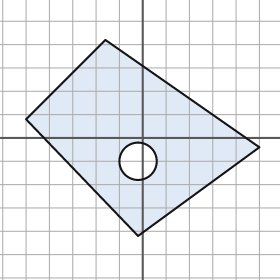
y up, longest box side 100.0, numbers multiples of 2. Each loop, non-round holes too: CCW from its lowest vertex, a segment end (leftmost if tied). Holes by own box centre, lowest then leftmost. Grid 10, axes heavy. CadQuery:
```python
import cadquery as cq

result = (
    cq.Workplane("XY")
    .moveTo(-2.0, -42.0)
    .lineTo(50.0, -4.0)
    .lineTo(-16.0, 42.0)
    .lineTo(-50.0, 8.0)
    .close()
    .moveTo(-2.0, -10.0)
    .circle(8.0)
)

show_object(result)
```